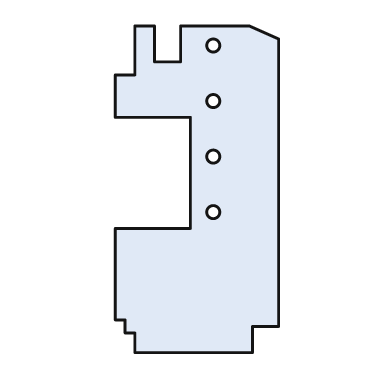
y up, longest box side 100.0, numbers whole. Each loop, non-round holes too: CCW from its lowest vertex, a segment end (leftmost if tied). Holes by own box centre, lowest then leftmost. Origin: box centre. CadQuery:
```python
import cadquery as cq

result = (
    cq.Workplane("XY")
    .moveTo(-19.0, -50.0)
    .lineTo(17.0, -50.0)
    .lineTo(17.0, -42.0)
    .lineTo(25.0, -42.0)
    .lineTo(25.0, 46.0)
    .lineTo(16.0, 50.0)
    .lineTo(-5.0, 50.0)
    .lineTo(-5.0, 39.0)
    .lineTo(-13.0, 39.0)
    .lineTo(-13.0, 50.0)
    .lineTo(-19.0, 50.0)
    .lineTo(-19.0, 35.0)
    .lineTo(-25.0, 35.0)
    .lineTo(-25.0, 22.0)
    .lineTo(-2.0, 22.0)
    .lineTo(-2.0, -12.0)
    .lineTo(-25.0, -12.0)
    .lineTo(-25.0, -40.0)
    .lineTo(-22.0, -40.0)
    .lineTo(-22.0, -44.0)
    .lineTo(-19.0, -44.0)
    .close()
    .moveTo(5.0, -7.0)
    .circle(2.0)
    .moveTo(5.0, 10.0)
    .circle(2.0)
    .moveTo(5.0, 27.0)
    .circle(2.0)
    .moveTo(5.0, 44.0)
    .circle(2.0)
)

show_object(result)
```